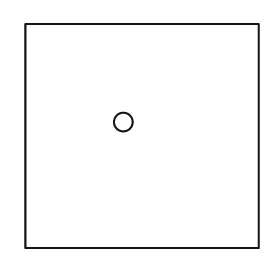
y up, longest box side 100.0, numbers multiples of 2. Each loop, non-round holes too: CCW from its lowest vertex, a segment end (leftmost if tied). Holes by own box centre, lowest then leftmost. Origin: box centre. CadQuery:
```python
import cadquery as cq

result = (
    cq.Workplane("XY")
    .moveTo(-50.0, -48.0)
    .lineTo(50.0, -48.0)
    .lineTo(50.0, 48.0)
    .lineTo(-50.0, 48.0)
    .close()
    .moveTo(-8.0, 6.0)
    .circle(4.0)
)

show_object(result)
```